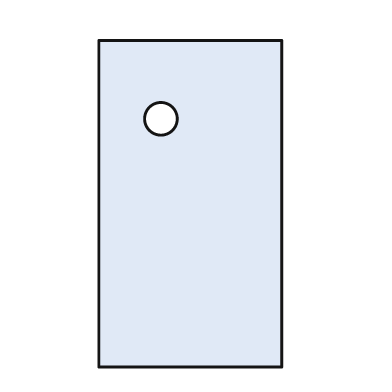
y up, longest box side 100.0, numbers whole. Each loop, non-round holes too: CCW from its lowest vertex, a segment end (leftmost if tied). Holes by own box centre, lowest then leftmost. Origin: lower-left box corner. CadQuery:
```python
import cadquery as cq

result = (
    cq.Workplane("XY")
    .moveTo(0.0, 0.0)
    .lineTo(56.0, 0.0)
    .lineTo(56.0, 100.0)
    .lineTo(0.0, 100.0)
    .close()
    .moveTo(19.0, 76.0)
    .circle(5.0)
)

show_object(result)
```